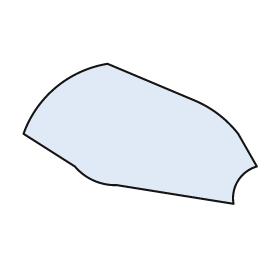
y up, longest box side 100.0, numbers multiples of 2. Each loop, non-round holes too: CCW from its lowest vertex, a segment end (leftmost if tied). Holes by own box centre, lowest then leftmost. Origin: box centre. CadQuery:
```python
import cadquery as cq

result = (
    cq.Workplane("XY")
    .moveTo(40.0, -30.0)
    .threePointArc((42.0, -20.0), (50.0, -14.0))
    .lineTo(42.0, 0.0)
    .threePointArc((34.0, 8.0), (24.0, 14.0))
    .lineTo(-14.0, 30.0)
    .threePointArc((-36.0, 20.0), (-50.0, 0.0))
    .lineTo(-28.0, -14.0)
    .threePointArc((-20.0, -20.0), (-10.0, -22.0))
    .close()
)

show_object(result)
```